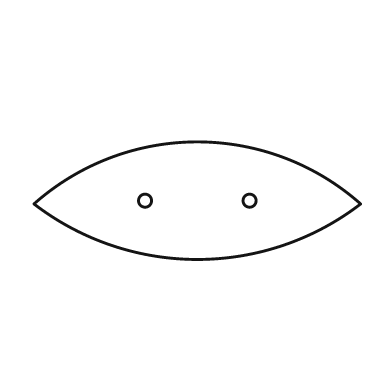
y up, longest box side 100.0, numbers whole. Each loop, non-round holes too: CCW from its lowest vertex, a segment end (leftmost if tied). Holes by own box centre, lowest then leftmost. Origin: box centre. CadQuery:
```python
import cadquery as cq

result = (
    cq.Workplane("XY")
    .moveTo(-50.0, -1.0)
    .threePointArc((0.0, -18.0), (50.0, -1.0))
    .threePointArc((0.0, 18.0), (-50.0, -1.0))
    .close()
    .moveTo(-16.0, 0.0)
    .circle(2.0)
    .moveTo(16.0, 0.0)
    .circle(2.0)
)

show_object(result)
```